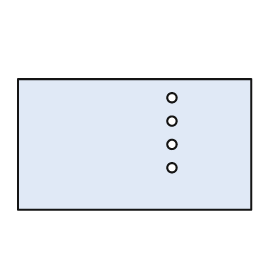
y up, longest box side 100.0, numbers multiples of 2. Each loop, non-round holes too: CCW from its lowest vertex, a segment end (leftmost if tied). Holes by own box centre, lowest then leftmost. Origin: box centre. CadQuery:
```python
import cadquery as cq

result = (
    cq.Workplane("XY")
    .moveTo(-50.0, -28.0)
    .lineTo(50.0, -28.0)
    .lineTo(50.0, 28.0)
    .lineTo(-50.0, 28.0)
    .close()
    .moveTo(16.0, -10.0)
    .circle(2.0)
    .moveTo(16.0, 0.0)
    .circle(2.0)
    .moveTo(16.0, 10.0)
    .circle(2.0)
    .moveTo(16.0, 20.0)
    .circle(2.0)
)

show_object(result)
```